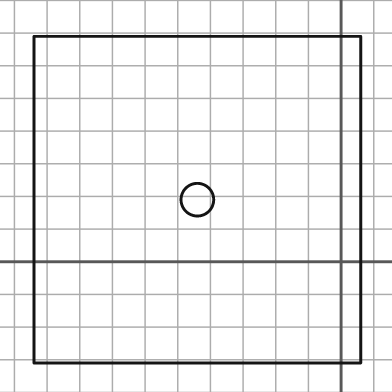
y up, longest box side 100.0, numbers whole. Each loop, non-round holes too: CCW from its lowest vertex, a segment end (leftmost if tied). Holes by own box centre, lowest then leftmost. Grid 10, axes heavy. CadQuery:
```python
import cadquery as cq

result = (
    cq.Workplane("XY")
    .moveTo(-94.0, -31.0)
    .lineTo(6.0, -31.0)
    .lineTo(6.0, 69.0)
    .lineTo(-94.0, 69.0)
    .close()
    .moveTo(-44.0, 19.0)
    .circle(5.0)
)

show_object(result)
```